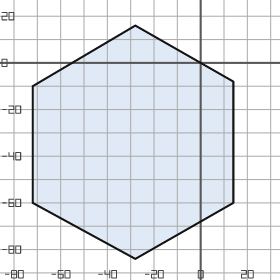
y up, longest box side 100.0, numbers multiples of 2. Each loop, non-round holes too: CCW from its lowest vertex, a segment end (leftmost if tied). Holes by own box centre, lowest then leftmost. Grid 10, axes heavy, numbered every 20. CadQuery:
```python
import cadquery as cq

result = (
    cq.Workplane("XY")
    .moveTo(-28.0, -84.0)
    .lineTo(14.0, -60.0)
    .lineTo(14.0, -8.0)
    .lineTo(-28.0, 16.0)
    .lineTo(-72.0, -10.0)
    .lineTo(-72.0, -60.0)
    .close()
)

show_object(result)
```